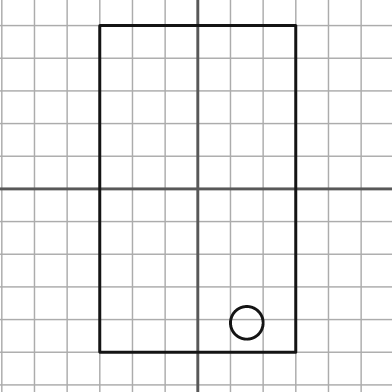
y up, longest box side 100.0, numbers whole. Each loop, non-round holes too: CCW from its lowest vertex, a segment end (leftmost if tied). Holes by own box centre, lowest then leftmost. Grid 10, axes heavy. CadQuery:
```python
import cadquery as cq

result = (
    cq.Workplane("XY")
    .moveTo(-30.0, -50.0)
    .lineTo(30.0, -50.0)
    .lineTo(30.0, 50.0)
    .lineTo(-30.0, 50.0)
    .close()
    .moveTo(15.0, -41.0)
    .circle(5.0)
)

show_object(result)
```